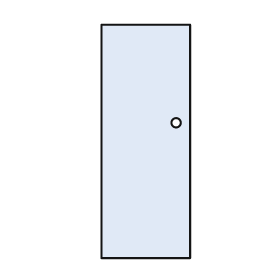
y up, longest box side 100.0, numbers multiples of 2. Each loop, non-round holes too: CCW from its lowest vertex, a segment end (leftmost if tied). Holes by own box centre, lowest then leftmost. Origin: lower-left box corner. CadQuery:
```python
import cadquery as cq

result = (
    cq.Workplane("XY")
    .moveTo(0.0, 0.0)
    .lineTo(38.0, 0.0)
    .lineTo(38.0, 100.0)
    .lineTo(0.0, 100.0)
    .close()
    .moveTo(32.0, 58.0)
    .circle(2.0)
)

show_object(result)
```